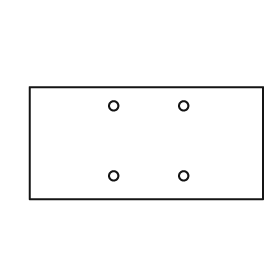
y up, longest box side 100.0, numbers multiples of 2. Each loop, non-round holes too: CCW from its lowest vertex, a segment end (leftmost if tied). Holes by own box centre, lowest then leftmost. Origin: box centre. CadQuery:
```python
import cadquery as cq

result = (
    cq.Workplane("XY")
    .moveTo(-50.0, -24.0)
    .lineTo(50.0, -24.0)
    .lineTo(50.0, 24.0)
    .lineTo(-50.0, 24.0)
    .close()
    .moveTo(-14.0, -14.0)
    .circle(2.0)
    .moveTo(16.0, -14.0)
    .circle(2.0)
    .moveTo(-14.0, 16.0)
    .circle(2.0)
    .moveTo(16.0, 16.0)
    .circle(2.0)
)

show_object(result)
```